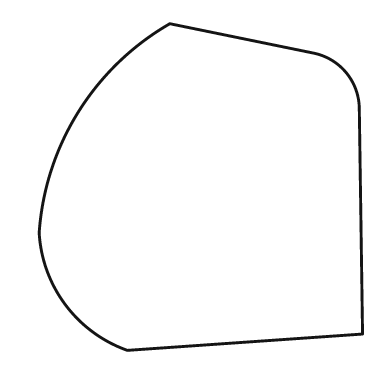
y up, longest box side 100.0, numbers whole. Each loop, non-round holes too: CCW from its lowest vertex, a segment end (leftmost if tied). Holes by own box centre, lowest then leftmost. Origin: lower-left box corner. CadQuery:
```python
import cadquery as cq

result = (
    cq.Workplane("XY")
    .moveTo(27.0, 0.0)
    .lineTo(99.0, 5.0)
    .lineTo(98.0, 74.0)
    .threePointArc((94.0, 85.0), (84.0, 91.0))
    .lineTo(40.0, 100.0)
    .threePointArc((12.0, 73.0), (0.0, 36.0))
    .threePointArc((8.0, 14.0), (27.0, 0.0))
    .close()
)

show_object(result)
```